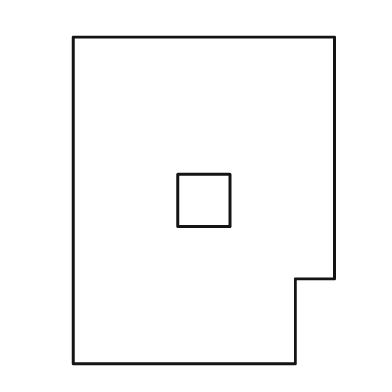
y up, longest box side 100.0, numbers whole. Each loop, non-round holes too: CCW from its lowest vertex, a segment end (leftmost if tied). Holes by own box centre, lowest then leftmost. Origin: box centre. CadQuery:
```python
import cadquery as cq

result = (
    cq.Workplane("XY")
    .moveTo(-40.0, -50.0)
    .lineTo(28.0, -50.0)
    .lineTo(28.0, -24.0)
    .lineTo(40.0, -24.0)
    .lineTo(40.0, 50.0)
    .lineTo(-40.0, 50.0)
    .close()
    .moveTo(-8.0, -8.0)
    .lineTo(8.0, -8.0)
    .lineTo(8.0, 8.0)
    .lineTo(-8.0, 8.0)
    .close()
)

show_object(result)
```